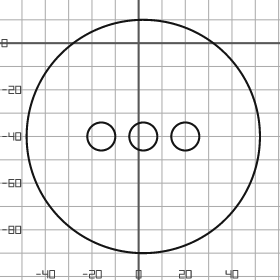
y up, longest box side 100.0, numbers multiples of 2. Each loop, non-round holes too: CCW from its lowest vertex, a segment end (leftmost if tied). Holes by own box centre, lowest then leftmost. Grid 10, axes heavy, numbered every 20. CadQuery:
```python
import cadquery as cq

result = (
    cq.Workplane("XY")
    .moveTo(2.0, -40.0)
    .circle(50.0)
    .moveTo(-16.0, -40.0)
    .circle(6.0)
    .moveTo(2.0, -40.0)
    .circle(6.0)
    .moveTo(20.0, -40.0)
    .circle(6.0)
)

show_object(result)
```